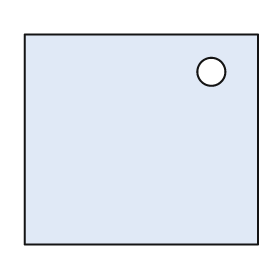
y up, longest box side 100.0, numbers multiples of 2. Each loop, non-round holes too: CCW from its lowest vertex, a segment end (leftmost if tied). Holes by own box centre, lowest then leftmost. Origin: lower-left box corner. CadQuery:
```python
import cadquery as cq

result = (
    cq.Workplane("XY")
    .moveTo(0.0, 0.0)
    .lineTo(100.0, 0.0)
    .lineTo(100.0, 90.0)
    .lineTo(0.0, 90.0)
    .close()
    .moveTo(80.0, 74.0)
    .circle(6.0)
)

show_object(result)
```